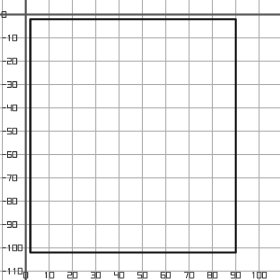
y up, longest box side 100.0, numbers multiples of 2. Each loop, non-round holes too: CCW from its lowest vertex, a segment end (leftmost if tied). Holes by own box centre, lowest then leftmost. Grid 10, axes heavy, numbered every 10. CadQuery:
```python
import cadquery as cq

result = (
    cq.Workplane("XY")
    .moveTo(2.0, -102.0)
    .lineTo(90.0, -102.0)
    .lineTo(90.0, -2.0)
    .lineTo(2.0, -2.0)
    .close()
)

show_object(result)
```